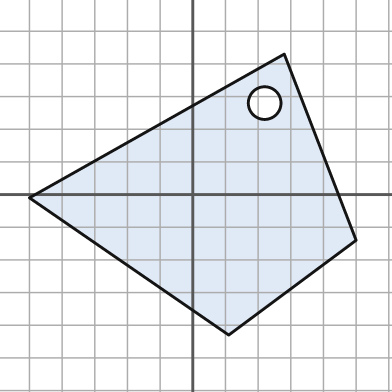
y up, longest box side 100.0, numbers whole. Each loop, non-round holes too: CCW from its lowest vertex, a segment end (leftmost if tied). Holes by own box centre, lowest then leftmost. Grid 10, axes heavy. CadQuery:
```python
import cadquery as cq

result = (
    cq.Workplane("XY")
    .moveTo(11.0, -43.0)
    .lineTo(50.0, -14.0)
    .lineTo(28.0, 43.0)
    .lineTo(-50.0, -1.0)
    .close()
    .moveTo(22.0, 28.0)
    .circle(5.0)
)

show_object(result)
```